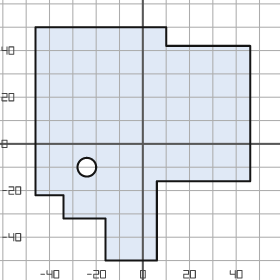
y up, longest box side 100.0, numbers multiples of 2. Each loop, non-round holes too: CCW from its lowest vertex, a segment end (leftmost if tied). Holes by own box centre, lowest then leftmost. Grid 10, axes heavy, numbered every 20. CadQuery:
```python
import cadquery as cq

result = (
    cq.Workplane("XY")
    .moveTo(-16.0, -50.0)
    .lineTo(6.0, -50.0)
    .lineTo(6.0, -16.0)
    .lineTo(46.0, -16.0)
    .lineTo(46.0, 42.0)
    .lineTo(10.0, 42.0)
    .lineTo(10.0, 50.0)
    .lineTo(-46.0, 50.0)
    .lineTo(-46.0, -22.0)
    .lineTo(-34.0, -22.0)
    .lineTo(-34.0, -32.0)
    .lineTo(-16.0, -32.0)
    .close()
    .moveTo(-24.0, -10.0)
    .circle(4.0)
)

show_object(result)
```